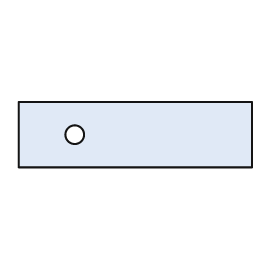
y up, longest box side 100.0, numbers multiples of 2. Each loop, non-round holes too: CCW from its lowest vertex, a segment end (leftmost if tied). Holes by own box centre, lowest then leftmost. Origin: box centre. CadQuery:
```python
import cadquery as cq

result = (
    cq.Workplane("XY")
    .moveTo(-50.0, -14.0)
    .lineTo(50.0, -14.0)
    .lineTo(50.0, 14.0)
    .lineTo(-50.0, 14.0)
    .close()
    .moveTo(-26.0, 0.0)
    .circle(4.0)
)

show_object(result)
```